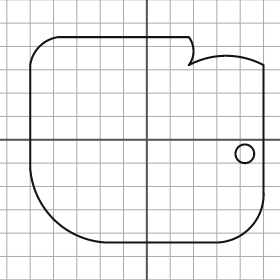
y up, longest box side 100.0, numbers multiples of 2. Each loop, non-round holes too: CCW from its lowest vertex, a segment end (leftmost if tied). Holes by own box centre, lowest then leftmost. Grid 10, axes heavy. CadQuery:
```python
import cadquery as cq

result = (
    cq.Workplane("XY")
    .moveTo(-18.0, -44.0)
    .lineTo(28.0, -44.0)
    .threePointArc((44.0, -38.0), (50.0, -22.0))
    .lineTo(50.0, 32.0)
    .threePointArc((34.0, 36.0), (18.0, 32.0))
    .threePointArc((20.0, 38.0), (18.0, 44.0))
    .lineTo(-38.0, 44.0)
    .threePointArc((-46.0, 40.0), (-50.0, 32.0))
    .lineTo(-50.0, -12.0)
    .threePointArc((-40.0, -34.0), (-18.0, -44.0))
    .close()
    .moveTo(42.0, -6.0)
    .circle(4.0)
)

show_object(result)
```